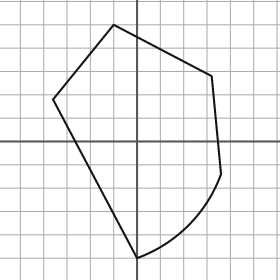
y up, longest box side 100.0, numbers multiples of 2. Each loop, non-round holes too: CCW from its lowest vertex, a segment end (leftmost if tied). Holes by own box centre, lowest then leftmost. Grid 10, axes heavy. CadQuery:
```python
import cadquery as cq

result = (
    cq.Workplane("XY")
    .moveTo(0.0, -50.0)
    .threePointArc((22.0, -36.0), (36.0, -14.0))
    .lineTo(32.0, 28.0)
    .lineTo(-10.0, 50.0)
    .lineTo(-36.0, 18.0)
    .close()
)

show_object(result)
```